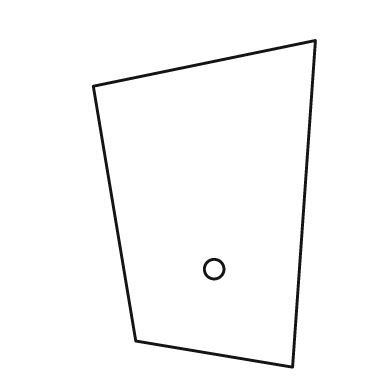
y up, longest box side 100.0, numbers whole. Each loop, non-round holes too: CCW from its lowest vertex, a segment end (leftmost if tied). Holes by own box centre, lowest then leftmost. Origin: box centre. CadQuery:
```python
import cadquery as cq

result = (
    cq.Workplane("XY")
    .moveTo(27.0, -50.0)
    .lineTo(34.0, 50.0)
    .lineTo(-34.0, 36.0)
    .lineTo(-21.0, -42.0)
    .close()
    .moveTo(3.0, -20.0)
    .circle(3.0)
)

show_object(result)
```